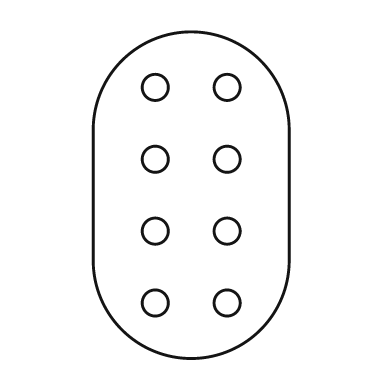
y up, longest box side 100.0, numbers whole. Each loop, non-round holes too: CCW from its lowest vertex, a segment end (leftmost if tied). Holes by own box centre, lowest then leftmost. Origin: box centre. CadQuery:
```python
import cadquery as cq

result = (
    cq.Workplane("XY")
    .moveTo(-30.0, -20.0)
    .threePointArc((0.0, -50.0), (30.0, -20.0))
    .lineTo(30.0, 20.0)
    .threePointArc((0.0, 50.0), (-30.0, 20.0))
    .close()
    .moveTo(-11.0, -33.0)
    .circle(4.0)
    .moveTo(11.0, -33.0)
    .circle(4.0)
    .moveTo(-11.0, -11.0)
    .circle(4.0)
    .moveTo(11.0, -11.0)
    .circle(4.0)
    .moveTo(-11.0, 11.0)
    .circle(4.0)
    .moveTo(11.0, 11.0)
    .circle(4.0)
    .moveTo(-11.0, 33.0)
    .circle(4.0)
    .moveTo(11.0, 33.0)
    .circle(4.0)
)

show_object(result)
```